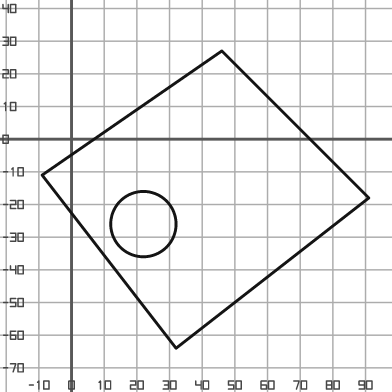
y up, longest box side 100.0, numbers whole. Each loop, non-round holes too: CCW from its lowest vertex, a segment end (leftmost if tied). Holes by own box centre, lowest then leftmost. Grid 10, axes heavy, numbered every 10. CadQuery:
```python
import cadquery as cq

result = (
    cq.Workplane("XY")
    .moveTo(32.0, -64.0)
    .lineTo(91.0, -18.0)
    .lineTo(46.0, 27.0)
    .lineTo(-9.0, -11.0)
    .close()
    .moveTo(22.0, -26.0)
    .circle(10.0)
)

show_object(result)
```